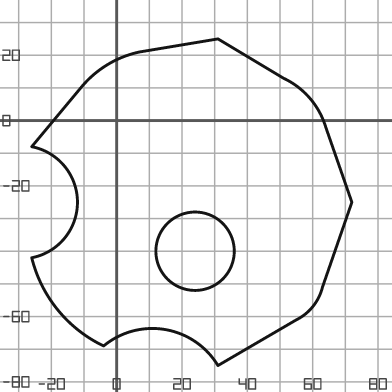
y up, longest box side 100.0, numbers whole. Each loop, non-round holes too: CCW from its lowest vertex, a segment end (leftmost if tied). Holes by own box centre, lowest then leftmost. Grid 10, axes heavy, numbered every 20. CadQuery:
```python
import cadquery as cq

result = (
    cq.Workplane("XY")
    .moveTo(31.0, -75.0)
    .lineTo(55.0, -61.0)
    .threePointArc((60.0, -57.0), (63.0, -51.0))
    .lineTo(72.0, -25.0)
    .lineTo(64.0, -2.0)
    .threePointArc((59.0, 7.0), (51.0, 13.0))
    .lineTo(31.0, 25.0)
    .lineTo(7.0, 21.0)
    .threePointArc((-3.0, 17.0), (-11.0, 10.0))
    .lineTo(-26.0, -8.0)
    .threePointArc((-12.0, -25.0), (-26.0, -42.0))
    .threePointArc((-18.0, -58.0), (-4.0, -69.0))
    .threePointArc((15.0, -64.0), (31.0, -75.0))
    .close()
    .moveTo(24.0, -40.0)
    .circle(12.0)
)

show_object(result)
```